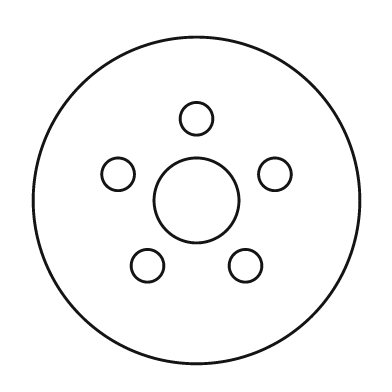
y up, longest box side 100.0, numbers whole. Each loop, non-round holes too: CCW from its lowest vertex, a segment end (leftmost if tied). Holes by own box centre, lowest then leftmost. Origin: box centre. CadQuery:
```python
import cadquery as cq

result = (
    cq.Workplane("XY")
    .moveTo(0.0, 0.0)
    .circle(50.0)
    .moveTo(-15.0, -20.0)
    .circle(5.0)
    .moveTo(15.0, -20.0)
    .circle(5.0)
    .moveTo(0.0, 0.0)
    .circle(13.0)
    .moveTo(-24.0, 8.0)
    .circle(5.0)
    .moveTo(24.0, 8.0)
    .circle(5.0)
    .moveTo(0.0, 25.0)
    .circle(5.0)
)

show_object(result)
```